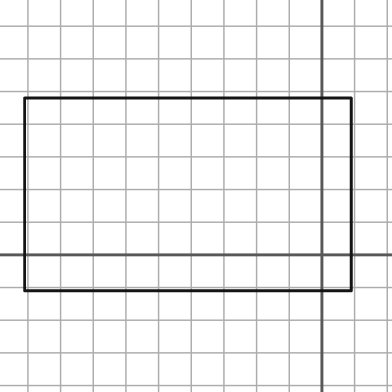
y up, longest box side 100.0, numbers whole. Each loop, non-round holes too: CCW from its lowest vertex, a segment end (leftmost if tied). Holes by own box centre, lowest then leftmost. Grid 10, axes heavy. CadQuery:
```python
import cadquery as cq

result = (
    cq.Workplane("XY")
    .moveTo(-91.0, -11.0)
    .lineTo(9.0, -11.0)
    .lineTo(9.0, 48.0)
    .lineTo(-91.0, 48.0)
    .close()
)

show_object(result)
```